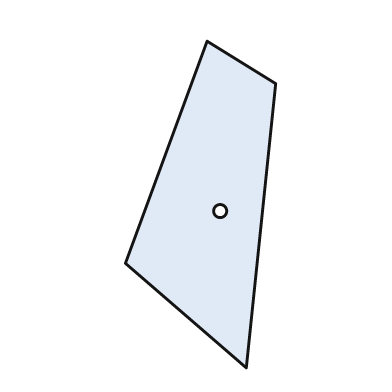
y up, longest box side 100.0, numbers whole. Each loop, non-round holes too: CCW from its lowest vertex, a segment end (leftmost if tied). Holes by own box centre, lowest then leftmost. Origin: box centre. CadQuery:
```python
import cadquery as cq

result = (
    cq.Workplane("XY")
    .moveTo(14.0, -50.0)
    .lineTo(23.0, 37.0)
    .lineTo(2.0, 50.0)
    .lineTo(-23.0, -18.0)
    .close()
    .moveTo(6.0, -2.0)
    .circle(2.0)
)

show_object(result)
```